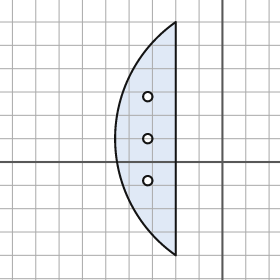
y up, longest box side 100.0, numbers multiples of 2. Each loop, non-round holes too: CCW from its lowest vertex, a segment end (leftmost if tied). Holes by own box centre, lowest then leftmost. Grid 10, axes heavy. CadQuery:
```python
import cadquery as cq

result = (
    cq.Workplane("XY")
    .moveTo(-20.0, -40.0)
    .lineTo(-20.0, 60.0)
    .threePointArc((-46.0, 10.0), (-20.0, -40.0))
    .close()
    .moveTo(-32.0, -8.0)
    .circle(2.0)
    .moveTo(-32.0, 10.0)
    .circle(2.0)
    .moveTo(-32.0, 28.0)
    .circle(2.0)
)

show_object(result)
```